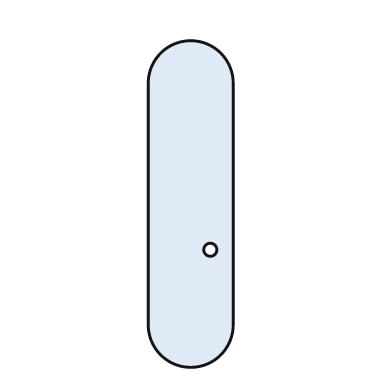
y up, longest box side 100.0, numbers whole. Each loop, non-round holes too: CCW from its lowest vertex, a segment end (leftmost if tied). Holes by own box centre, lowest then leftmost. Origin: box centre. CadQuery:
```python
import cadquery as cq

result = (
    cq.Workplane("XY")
    .moveTo(-13.0, -37.0)
    .threePointArc((0.0, -50.0), (13.0, -37.0))
    .lineTo(13.0, 37.0)
    .threePointArc((0.0, 50.0), (-13.0, 37.0))
    .close()
    .moveTo(6.0, -14.0)
    .circle(2.0)
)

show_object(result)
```